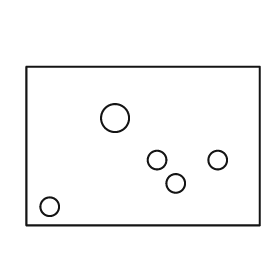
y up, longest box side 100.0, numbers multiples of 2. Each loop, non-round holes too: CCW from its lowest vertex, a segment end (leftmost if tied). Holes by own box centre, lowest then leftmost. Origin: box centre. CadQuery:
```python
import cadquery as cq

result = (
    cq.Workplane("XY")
    .moveTo(-50.0, -34.0)
    .lineTo(50.0, -34.0)
    .lineTo(50.0, 34.0)
    .lineTo(-50.0, 34.0)
    .close()
    .moveTo(-40.0, -26.0)
    .circle(4.0)
    .moveTo(14.0, -16.0)
    .circle(4.0)
    .moveTo(6.0, -6.0)
    .circle(4.0)
    .moveTo(32.0, -6.0)
    .circle(4.0)
    .moveTo(-12.0, 12.0)
    .circle(6.0)
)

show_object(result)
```